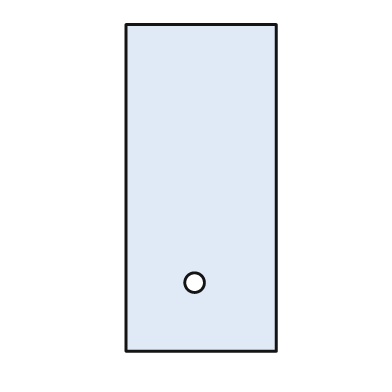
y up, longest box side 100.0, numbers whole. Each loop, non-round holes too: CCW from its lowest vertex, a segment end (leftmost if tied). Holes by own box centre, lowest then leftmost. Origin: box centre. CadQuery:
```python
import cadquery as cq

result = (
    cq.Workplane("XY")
    .moveTo(-23.0, -50.0)
    .lineTo(23.0, -50.0)
    .lineTo(23.0, 50.0)
    .lineTo(-23.0, 50.0)
    .close()
    .moveTo(-2.0, -29.0)
    .circle(3.0)
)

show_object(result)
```